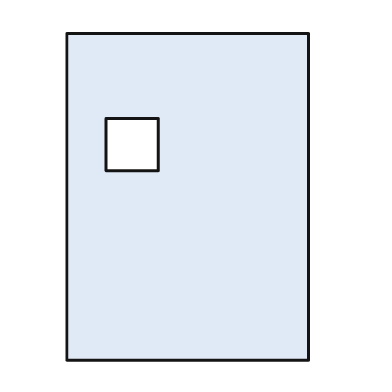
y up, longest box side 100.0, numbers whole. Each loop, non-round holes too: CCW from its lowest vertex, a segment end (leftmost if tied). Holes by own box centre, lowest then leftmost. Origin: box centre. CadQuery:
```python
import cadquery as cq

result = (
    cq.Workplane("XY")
    .moveTo(-37.0, -50.0)
    .lineTo(37.0, -50.0)
    .lineTo(37.0, 50.0)
    .lineTo(-37.0, 50.0)
    .close()
    .moveTo(-25.0, 8.0)
    .lineTo(-9.0, 8.0)
    .lineTo(-9.0, 24.0)
    .lineTo(-25.0, 24.0)
    .close()
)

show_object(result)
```